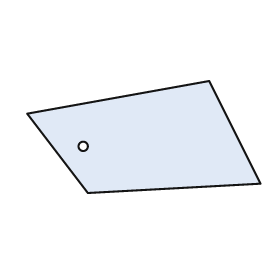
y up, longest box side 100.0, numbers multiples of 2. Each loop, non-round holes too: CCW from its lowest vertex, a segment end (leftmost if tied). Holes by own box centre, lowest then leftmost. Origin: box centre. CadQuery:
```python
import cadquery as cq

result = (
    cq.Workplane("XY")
    .moveTo(-24.0, -24.0)
    .lineTo(50.0, -20.0)
    .lineTo(28.0, 24.0)
    .lineTo(-50.0, 10.0)
    .close()
    .moveTo(-26.0, -4.0)
    .circle(2.0)
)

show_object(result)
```